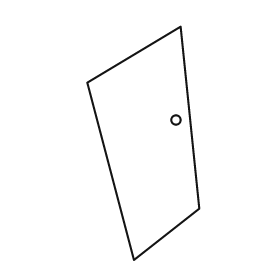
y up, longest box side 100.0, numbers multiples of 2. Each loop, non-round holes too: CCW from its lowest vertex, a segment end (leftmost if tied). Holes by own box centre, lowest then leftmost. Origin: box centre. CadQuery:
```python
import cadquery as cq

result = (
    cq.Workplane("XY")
    .moveTo(-4.0, -50.0)
    .lineTo(24.0, -28.0)
    .lineTo(16.0, 50.0)
    .lineTo(-24.0, 26.0)
    .close()
    .moveTo(14.0, 10.0)
    .circle(2.0)
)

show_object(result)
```